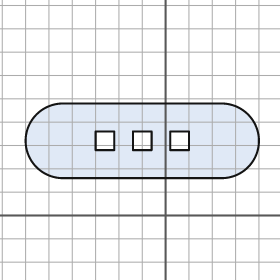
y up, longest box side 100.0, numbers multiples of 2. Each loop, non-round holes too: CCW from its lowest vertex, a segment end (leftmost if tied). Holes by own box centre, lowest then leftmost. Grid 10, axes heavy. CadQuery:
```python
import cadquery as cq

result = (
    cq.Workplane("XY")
    .moveTo(-44.0, 16.0)
    .lineTo(24.0, 16.0)
    .threePointArc((40.0, 32.0), (24.0, 48.0))
    .lineTo(-44.0, 48.0)
    .threePointArc((-60.0, 32.0), (-44.0, 16.0))
    .close()
    .moveTo(-30.0, 28.0)
    .lineTo(-22.0, 28.0)
    .lineTo(-22.0, 36.0)
    .lineTo(-30.0, 36.0)
    .close()
    .moveTo(-14.0, 28.0)
    .lineTo(-6.0, 28.0)
    .lineTo(-6.0, 36.0)
    .lineTo(-14.0, 36.0)
    .close()
    .moveTo(2.0, 28.0)
    .lineTo(10.0, 28.0)
    .lineTo(10.0, 36.0)
    .lineTo(2.0, 36.0)
    .close()
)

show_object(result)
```